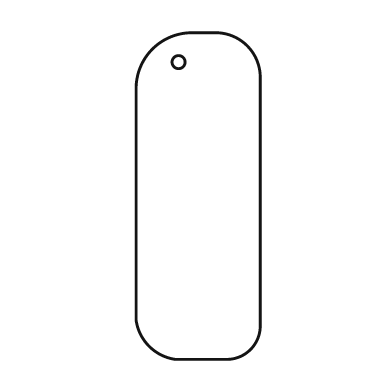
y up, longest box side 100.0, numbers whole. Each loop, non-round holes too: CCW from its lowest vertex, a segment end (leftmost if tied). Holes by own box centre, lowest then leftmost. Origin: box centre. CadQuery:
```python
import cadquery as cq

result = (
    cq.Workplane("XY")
    .moveTo(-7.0, -50.0)
    .lineTo(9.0, -50.0)
    .threePointArc((16.0, -47.0), (19.0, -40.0))
    .lineTo(19.0, 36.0)
    .threePointArc((15.0, 46.0), (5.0, 50.0))
    .lineTo(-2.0, 50.0)
    .threePointArc((-14.0, 45.0), (-19.0, 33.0))
    .lineTo(-19.0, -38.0)
    .threePointArc((-15.0, -46.0), (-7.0, -50.0))
    .close()
    .moveTo(-6.0, 41.0)
    .circle(2.0)
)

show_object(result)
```